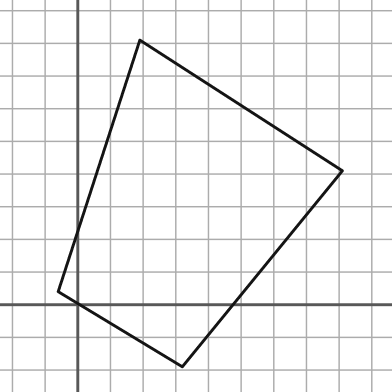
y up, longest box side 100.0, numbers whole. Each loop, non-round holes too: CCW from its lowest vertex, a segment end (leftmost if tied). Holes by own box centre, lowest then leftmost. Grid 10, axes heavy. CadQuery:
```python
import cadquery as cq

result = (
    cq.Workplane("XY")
    .moveTo(32.0, -19.0)
    .lineTo(81.0, 41.0)
    .lineTo(19.0, 81.0)
    .lineTo(-6.0, 4.0)
    .close()
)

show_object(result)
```